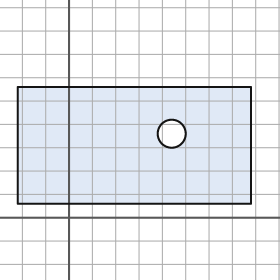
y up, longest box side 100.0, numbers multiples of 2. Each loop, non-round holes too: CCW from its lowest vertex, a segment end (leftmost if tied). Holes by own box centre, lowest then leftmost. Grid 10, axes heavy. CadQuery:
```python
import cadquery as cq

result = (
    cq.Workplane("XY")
    .moveTo(-22.0, 6.0)
    .lineTo(78.0, 6.0)
    .lineTo(78.0, 56.0)
    .lineTo(-22.0, 56.0)
    .close()
    .moveTo(44.0, 36.0)
    .circle(6.0)
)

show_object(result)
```